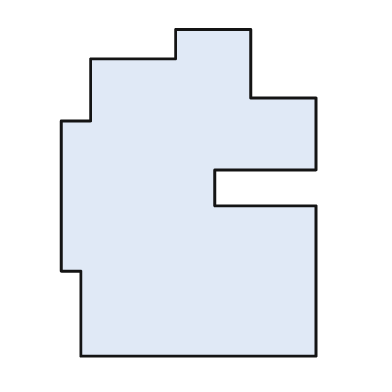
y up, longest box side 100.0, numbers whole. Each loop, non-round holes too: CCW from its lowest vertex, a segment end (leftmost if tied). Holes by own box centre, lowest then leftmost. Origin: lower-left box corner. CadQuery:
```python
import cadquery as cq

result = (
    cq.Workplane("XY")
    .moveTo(6.0, 0.0)
    .lineTo(78.0, 0.0)
    .lineTo(78.0, 46.0)
    .lineTo(47.0, 46.0)
    .lineTo(47.0, 57.0)
    .lineTo(78.0, 57.0)
    .lineTo(78.0, 79.0)
    .lineTo(58.0, 79.0)
    .lineTo(58.0, 100.0)
    .lineTo(35.0, 100.0)
    .lineTo(35.0, 91.0)
    .lineTo(9.0, 91.0)
    .lineTo(9.0, 72.0)
    .lineTo(0.0, 72.0)
    .lineTo(0.0, 26.0)
    .lineTo(6.0, 26.0)
    .close()
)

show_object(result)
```